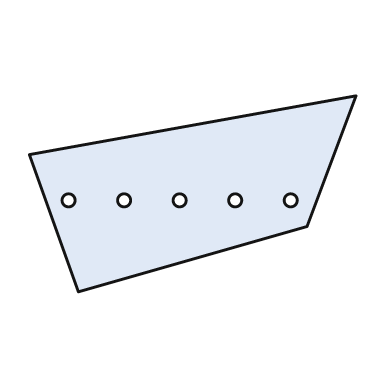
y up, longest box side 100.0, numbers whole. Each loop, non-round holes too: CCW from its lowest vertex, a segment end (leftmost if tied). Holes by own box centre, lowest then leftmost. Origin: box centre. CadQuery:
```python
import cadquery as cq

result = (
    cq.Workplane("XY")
    .moveTo(-35.0, -30.0)
    .lineTo(35.0, -10.0)
    .lineTo(50.0, 30.0)
    .lineTo(-50.0, 12.0)
    .close()
    .moveTo(-38.0, -2.0)
    .circle(2.0)
    .moveTo(-21.0, -2.0)
    .circle(2.0)
    .moveTo(-4.0, -2.0)
    .circle(2.0)
    .moveTo(13.0, -2.0)
    .circle(2.0)
    .moveTo(30.0, -2.0)
    .circle(2.0)
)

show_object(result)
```